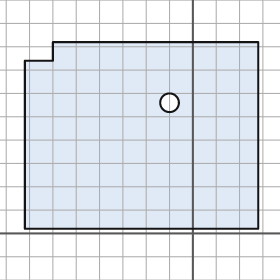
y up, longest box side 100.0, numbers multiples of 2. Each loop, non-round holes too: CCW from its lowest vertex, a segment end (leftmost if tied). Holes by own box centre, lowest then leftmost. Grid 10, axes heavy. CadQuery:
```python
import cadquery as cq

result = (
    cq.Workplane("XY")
    .moveTo(-72.0, 2.0)
    .lineTo(28.0, 2.0)
    .lineTo(28.0, 82.0)
    .lineTo(-60.0, 82.0)
    .lineTo(-60.0, 74.0)
    .lineTo(-72.0, 74.0)
    .close()
    .moveTo(-10.0, 56.0)
    .circle(4.0)
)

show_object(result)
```